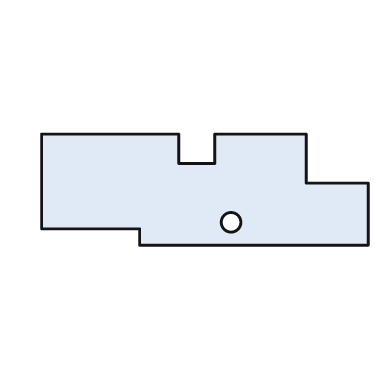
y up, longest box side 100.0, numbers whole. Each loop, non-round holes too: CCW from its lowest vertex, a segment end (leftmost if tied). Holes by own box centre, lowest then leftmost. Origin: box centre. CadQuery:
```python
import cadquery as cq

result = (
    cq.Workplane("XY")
    .moveTo(-20.0, -17.0)
    .lineTo(50.0, -17.0)
    .lineTo(50.0, 2.0)
    .lineTo(31.0, 2.0)
    .lineTo(31.0, 17.0)
    .lineTo(3.0, 17.0)
    .lineTo(3.0, 8.0)
    .lineTo(-8.0, 8.0)
    .lineTo(-8.0, 17.0)
    .lineTo(-50.0, 17.0)
    .lineTo(-50.0, -12.0)
    .lineTo(-20.0, -12.0)
    .close()
    .moveTo(8.0, -10.0)
    .circle(3.0)
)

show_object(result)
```